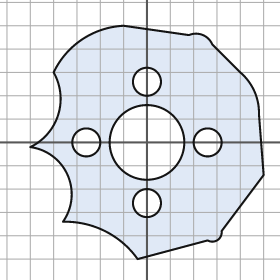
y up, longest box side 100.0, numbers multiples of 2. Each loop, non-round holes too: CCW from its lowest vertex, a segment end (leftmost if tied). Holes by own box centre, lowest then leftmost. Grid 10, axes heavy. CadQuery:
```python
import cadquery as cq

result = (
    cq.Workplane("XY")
    .moveTo(-4.0, -50.0)
    .lineTo(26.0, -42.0)
    .threePointArc((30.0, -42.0), (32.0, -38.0))
    .lineTo(50.0, -14.0)
    .lineTo(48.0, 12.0)
    .threePointArc((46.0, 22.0), (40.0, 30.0))
    .lineTo(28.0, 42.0)
    .threePointArc((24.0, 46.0), (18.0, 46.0))
    .lineTo(-10.0, 50.0)
    .threePointArc((-28.0, 44.0), (-40.0, 30.0))
    .threePointArc((-38.0, 12.0), (-50.0, -2.0))
    .threePointArc((-34.0, -14.0), (-36.0, -34.0))
    .threePointArc((-18.0, -38.0), (-4.0, -50.0))
    .close()
    .moveTo(0.0, -26.0)
    .circle(6.0)
    .moveTo(-26.0, 0.0)
    .circle(6.0)
    .moveTo(0.0, 0.0)
    .circle(16.0)
    .moveTo(26.0, 0.0)
    .circle(6.0)
    .moveTo(0.0, 26.0)
    .circle(6.0)
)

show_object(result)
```